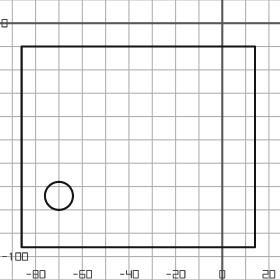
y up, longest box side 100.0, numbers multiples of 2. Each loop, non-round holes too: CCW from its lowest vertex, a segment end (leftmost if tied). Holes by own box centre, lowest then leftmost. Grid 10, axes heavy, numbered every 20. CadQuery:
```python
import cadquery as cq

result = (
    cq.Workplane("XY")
    .moveTo(-86.0, -96.0)
    .lineTo(14.0, -96.0)
    .lineTo(14.0, -10.0)
    .lineTo(-86.0, -10.0)
    .close()
    .moveTo(-70.0, -74.0)
    .circle(6.0)
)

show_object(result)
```